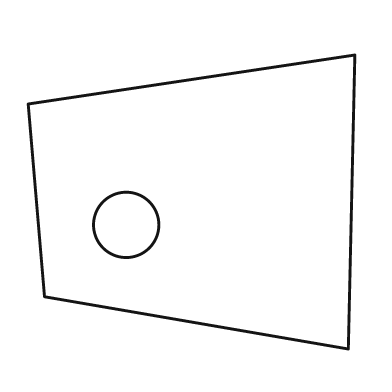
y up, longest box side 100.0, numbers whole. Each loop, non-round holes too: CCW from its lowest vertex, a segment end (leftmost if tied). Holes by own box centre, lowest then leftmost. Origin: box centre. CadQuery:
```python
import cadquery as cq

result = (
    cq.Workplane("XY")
    .moveTo(48.0, -45.0)
    .lineTo(50.0, 45.0)
    .lineTo(-50.0, 30.0)
    .lineTo(-45.0, -29.0)
    .close()
    .moveTo(-20.0, -7.0)
    .circle(10.0)
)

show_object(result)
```